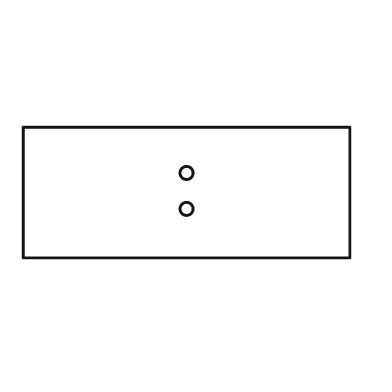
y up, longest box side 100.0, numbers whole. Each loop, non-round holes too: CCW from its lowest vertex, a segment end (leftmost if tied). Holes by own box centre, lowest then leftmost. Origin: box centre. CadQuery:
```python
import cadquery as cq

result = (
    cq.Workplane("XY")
    .moveTo(-50.0, -20.0)
    .lineTo(50.0, -20.0)
    .lineTo(50.0, 20.0)
    .lineTo(-50.0, 20.0)
    .close()
    .moveTo(0.0, -5.0)
    .circle(2.0)
    .moveTo(0.0, 6.0)
    .circle(2.0)
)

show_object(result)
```